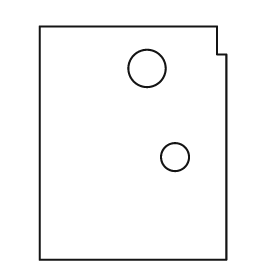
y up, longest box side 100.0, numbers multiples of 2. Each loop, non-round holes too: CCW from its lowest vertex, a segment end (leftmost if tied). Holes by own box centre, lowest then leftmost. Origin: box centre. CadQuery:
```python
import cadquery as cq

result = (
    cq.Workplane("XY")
    .moveTo(-40.0, -50.0)
    .lineTo(40.0, -50.0)
    .lineTo(40.0, 38.0)
    .lineTo(36.0, 38.0)
    .lineTo(36.0, 50.0)
    .lineTo(-40.0, 50.0)
    .close()
    .moveTo(18.0, -6.0)
    .circle(6.0)
    .moveTo(6.0, 32.0)
    .circle(8.0)
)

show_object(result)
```